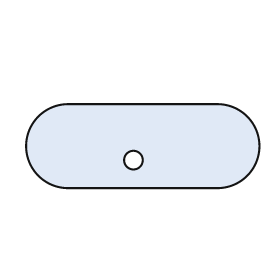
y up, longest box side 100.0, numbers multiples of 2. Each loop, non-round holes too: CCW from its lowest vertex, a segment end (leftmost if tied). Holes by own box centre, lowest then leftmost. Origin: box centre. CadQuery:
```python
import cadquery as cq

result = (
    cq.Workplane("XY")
    .moveTo(-32.0, -18.0)
    .lineTo(32.0, -18.0)
    .threePointArc((50.0, 0.0), (32.0, 18.0))
    .lineTo(-32.0, 18.0)
    .threePointArc((-50.0, 0.0), (-32.0, -18.0))
    .close()
    .moveTo(-4.0, -6.0)
    .circle(4.0)
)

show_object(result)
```